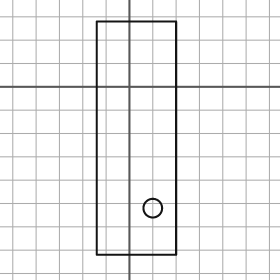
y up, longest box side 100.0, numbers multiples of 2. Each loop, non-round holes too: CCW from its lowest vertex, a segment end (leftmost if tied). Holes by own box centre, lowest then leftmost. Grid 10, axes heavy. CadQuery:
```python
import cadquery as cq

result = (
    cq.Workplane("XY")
    .moveTo(-14.0, -72.0)
    .lineTo(20.0, -72.0)
    .lineTo(20.0, 28.0)
    .lineTo(-14.0, 28.0)
    .close()
    .moveTo(10.0, -52.0)
    .circle(4.0)
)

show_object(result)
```